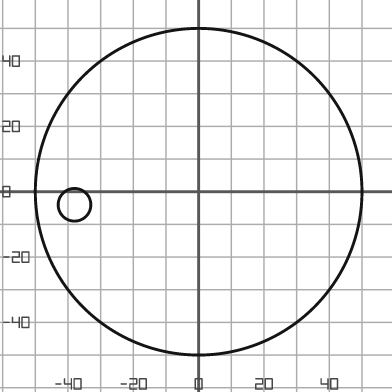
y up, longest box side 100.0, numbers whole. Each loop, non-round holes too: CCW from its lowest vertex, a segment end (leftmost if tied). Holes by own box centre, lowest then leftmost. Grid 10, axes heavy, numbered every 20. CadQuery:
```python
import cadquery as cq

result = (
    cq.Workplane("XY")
    .moveTo(0.0, 0.0)
    .circle(50.0)
    .moveTo(-38.0, -4.0)
    .circle(5.0)
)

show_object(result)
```